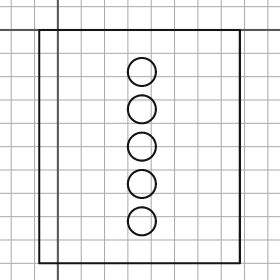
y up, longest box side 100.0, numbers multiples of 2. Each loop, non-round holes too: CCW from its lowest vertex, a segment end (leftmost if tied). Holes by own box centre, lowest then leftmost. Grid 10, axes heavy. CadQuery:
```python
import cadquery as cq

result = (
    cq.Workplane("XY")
    .moveTo(-8.0, -100.0)
    .lineTo(78.0, -100.0)
    .lineTo(78.0, 0.0)
    .lineTo(-8.0, 0.0)
    .close()
    .moveTo(36.0, -82.0)
    .circle(6.0)
    .moveTo(36.0, -66.0)
    .circle(6.0)
    .moveTo(36.0, -50.0)
    .circle(6.0)
    .moveTo(36.0, -34.0)
    .circle(6.0)
    .moveTo(36.0, -18.0)
    .circle(6.0)
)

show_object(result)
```